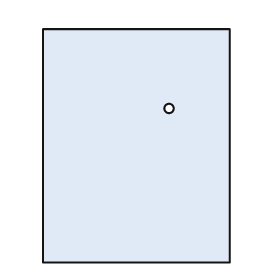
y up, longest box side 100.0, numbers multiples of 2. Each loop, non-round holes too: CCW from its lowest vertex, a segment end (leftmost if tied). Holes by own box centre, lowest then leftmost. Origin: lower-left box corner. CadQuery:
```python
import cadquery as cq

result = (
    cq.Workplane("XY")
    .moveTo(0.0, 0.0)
    .lineTo(80.0, 0.0)
    .lineTo(80.0, 100.0)
    .lineTo(0.0, 100.0)
    .close()
    .moveTo(54.0, 66.0)
    .circle(2.0)
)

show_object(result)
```